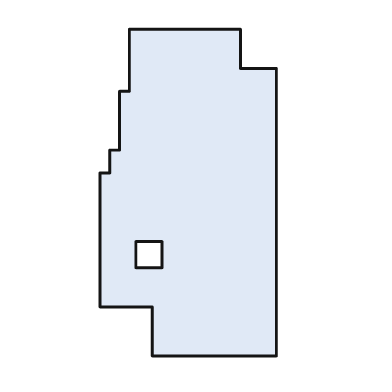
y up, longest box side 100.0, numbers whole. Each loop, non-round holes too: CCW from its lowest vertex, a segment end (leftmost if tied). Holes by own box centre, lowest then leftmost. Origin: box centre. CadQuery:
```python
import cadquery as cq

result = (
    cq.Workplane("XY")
    .moveTo(-11.0, -50.0)
    .lineTo(27.0, -50.0)
    .lineTo(27.0, 38.0)
    .lineTo(16.0, 38.0)
    .lineTo(16.0, 50.0)
    .lineTo(-18.0, 50.0)
    .lineTo(-18.0, 31.0)
    .lineTo(-21.0, 31.0)
    .lineTo(-21.0, 13.0)
    .lineTo(-24.0, 13.0)
    .lineTo(-24.0, 6.0)
    .lineTo(-27.0, 6.0)
    .lineTo(-27.0, -35.0)
    .lineTo(-11.0, -35.0)
    .close()
    .moveTo(-16.0, -23.0)
    .lineTo(-8.0, -23.0)
    .lineTo(-8.0, -15.0)
    .lineTo(-16.0, -15.0)
    .close()
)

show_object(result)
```